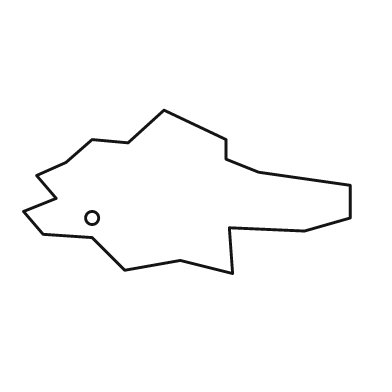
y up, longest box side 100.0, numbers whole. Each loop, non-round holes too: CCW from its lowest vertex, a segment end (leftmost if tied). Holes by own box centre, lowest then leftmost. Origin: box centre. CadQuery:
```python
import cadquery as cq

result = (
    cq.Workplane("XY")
    .moveTo(14.0, -25.0)
    .lineTo(13.0, -11.0)
    .lineTo(36.0, -12.0)
    .lineTo(50.0, -8.0)
    .lineTo(50.0, 2.0)
    .lineTo(22.0, 6.0)
    .lineTo(12.0, 10.0)
    .lineTo(12.0, 16.0)
    .lineTo(-7.0, 25.0)
    .lineTo(-18.0, 15.0)
    .lineTo(-29.0, 16.0)
    .lineTo(-37.0, 9.0)
    .lineTo(-46.0, 5.0)
    .lineTo(-40.0, -2.0)
    .lineTo(-50.0, -6.0)
    .lineTo(-44.0, -13.0)
    .lineTo(-29.0, -14.0)
    .lineTo(-19.0, -24.0)
    .lineTo(-2.0, -21.0)
    .close()
    .moveTo(-29.0, -8.0)
    .circle(2.0)
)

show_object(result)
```